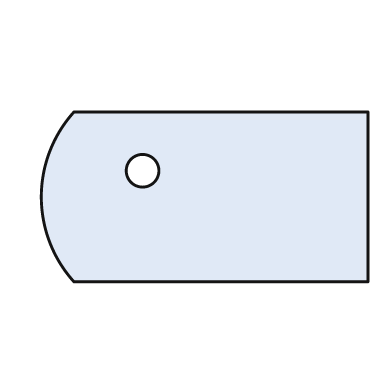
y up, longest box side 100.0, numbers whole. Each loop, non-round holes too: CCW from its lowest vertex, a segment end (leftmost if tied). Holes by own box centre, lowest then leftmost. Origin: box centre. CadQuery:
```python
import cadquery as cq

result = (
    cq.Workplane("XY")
    .moveTo(-40.0, -26.0)
    .lineTo(50.0, -26.0)
    .lineTo(50.0, 26.0)
    .lineTo(-40.0, 26.0)
    .threePointArc((-50.0, 0.0), (-40.0, -26.0))
    .close()
    .moveTo(-19.0, 8.0)
    .circle(5.0)
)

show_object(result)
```